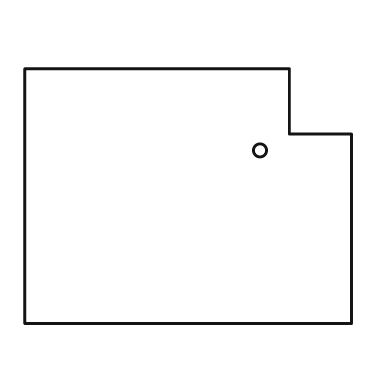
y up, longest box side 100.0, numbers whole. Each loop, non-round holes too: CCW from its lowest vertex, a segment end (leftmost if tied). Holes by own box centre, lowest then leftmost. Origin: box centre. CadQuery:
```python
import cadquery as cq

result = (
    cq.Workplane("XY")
    .moveTo(-50.0, -39.0)
    .lineTo(50.0, -39.0)
    .lineTo(50.0, 19.0)
    .lineTo(31.0, 19.0)
    .lineTo(31.0, 39.0)
    .lineTo(-50.0, 39.0)
    .close()
    .moveTo(22.0, 14.0)
    .circle(2.0)
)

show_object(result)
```